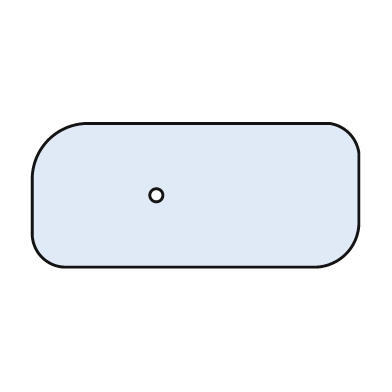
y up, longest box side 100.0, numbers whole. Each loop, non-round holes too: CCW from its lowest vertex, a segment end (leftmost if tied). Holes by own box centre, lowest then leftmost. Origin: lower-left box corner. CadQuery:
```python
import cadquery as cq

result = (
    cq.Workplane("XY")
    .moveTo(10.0, 0.0)
    .lineTo(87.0, 0.0)
    .threePointArc((96.0, 4.0), (100.0, 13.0))
    .lineTo(100.0, 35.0)
    .threePointArc((97.0, 41.0), (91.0, 44.0))
    .lineTo(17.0, 44.0)
    .threePointArc((5.0, 39.0), (0.0, 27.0))
    .lineTo(0.0, 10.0)
    .threePointArc((3.0, 3.0), (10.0, 0.0))
    .close()
    .moveTo(38.0, 22.0)
    .circle(2.0)
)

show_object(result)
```